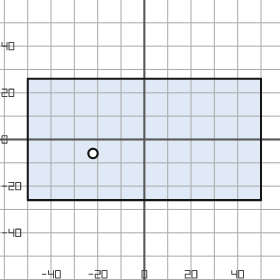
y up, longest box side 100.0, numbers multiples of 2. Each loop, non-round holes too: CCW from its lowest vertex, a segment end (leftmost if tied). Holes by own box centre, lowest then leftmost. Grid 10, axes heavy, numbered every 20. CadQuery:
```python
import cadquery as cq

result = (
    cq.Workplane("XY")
    .moveTo(-50.0, -26.0)
    .lineTo(50.0, -26.0)
    .lineTo(50.0, 26.0)
    .lineTo(-50.0, 26.0)
    .close()
    .moveTo(-22.0, -6.0)
    .circle(2.0)
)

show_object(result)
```